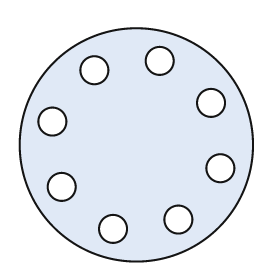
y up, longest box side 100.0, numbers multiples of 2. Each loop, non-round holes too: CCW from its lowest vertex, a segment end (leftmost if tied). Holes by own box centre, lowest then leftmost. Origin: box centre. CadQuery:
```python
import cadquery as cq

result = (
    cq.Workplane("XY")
    .moveTo(0.0, 0.0)
    .circle(50.0)
    .moveTo(-10.0, -36.0)
    .circle(6.0)
    .moveTo(18.0, -32.0)
    .circle(6.0)
    .moveTo(-32.0, -18.0)
    .circle(6.0)
    .moveTo(36.0, -10.0)
    .circle(6.0)
    .moveTo(-36.0, 10.0)
    .circle(6.0)
    .moveTo(32.0, 18.0)
    .circle(6.0)
    .moveTo(-18.0, 32.0)
    .circle(6.0)
    .moveTo(10.0, 36.0)
    .circle(6.0)
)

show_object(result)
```